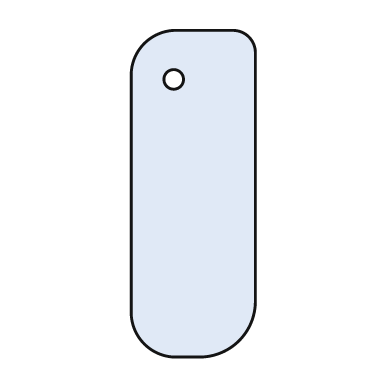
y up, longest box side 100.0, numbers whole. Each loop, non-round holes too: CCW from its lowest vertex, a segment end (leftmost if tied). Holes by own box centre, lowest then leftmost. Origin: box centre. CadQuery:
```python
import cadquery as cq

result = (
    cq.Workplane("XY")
    .moveTo(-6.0, -50.0)
    .lineTo(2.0, -50.0)
    .threePointArc((14.0, -45.0), (19.0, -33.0))
    .lineTo(19.0, 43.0)
    .threePointArc((17.0, 48.0), (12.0, 50.0))
    .lineTo(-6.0, 50.0)
    .threePointArc((-15.0, 46.0), (-19.0, 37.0))
    .lineTo(-19.0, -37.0)
    .threePointArc((-15.0, -46.0), (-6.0, -50.0))
    .close()
    .moveTo(-6.0, 35.0)
    .circle(3.0)
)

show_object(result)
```